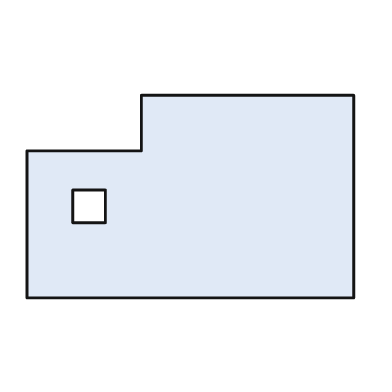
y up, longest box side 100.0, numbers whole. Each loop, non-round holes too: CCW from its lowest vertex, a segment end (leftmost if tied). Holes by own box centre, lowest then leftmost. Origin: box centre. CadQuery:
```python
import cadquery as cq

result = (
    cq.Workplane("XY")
    .moveTo(-50.0, -31.0)
    .lineTo(50.0, -31.0)
    .lineTo(50.0, 31.0)
    .lineTo(-15.0, 31.0)
    .lineTo(-15.0, 14.0)
    .lineTo(-50.0, 14.0)
    .close()
    .moveTo(-36.0, -8.0)
    .lineTo(-26.0, -8.0)
    .lineTo(-26.0, 2.0)
    .lineTo(-36.0, 2.0)
    .close()
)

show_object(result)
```